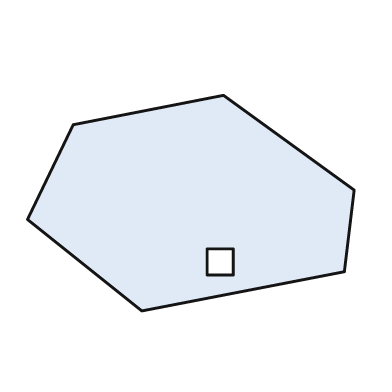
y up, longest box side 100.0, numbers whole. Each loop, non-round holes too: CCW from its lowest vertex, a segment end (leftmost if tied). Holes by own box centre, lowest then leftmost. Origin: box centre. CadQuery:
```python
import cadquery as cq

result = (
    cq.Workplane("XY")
    .moveTo(-15.0, -33.0)
    .lineTo(47.0, -21.0)
    .lineTo(50.0, 4.0)
    .lineTo(10.0, 33.0)
    .lineTo(-36.0, 24.0)
    .lineTo(-50.0, -5.0)
    .close()
    .moveTo(5.0, -22.0)
    .lineTo(13.0, -22.0)
    .lineTo(13.0, -14.0)
    .lineTo(5.0, -14.0)
    .close()
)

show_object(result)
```